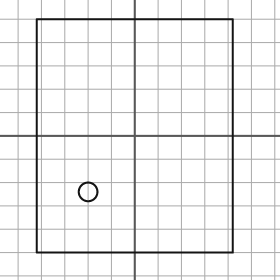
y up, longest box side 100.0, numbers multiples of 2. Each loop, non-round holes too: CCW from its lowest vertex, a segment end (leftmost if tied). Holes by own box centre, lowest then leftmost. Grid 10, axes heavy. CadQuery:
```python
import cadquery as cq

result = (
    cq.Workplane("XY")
    .moveTo(-42.0, -50.0)
    .lineTo(42.0, -50.0)
    .lineTo(42.0, 50.0)
    .lineTo(-42.0, 50.0)
    .close()
    .moveTo(-20.0, -24.0)
    .circle(4.0)
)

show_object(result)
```